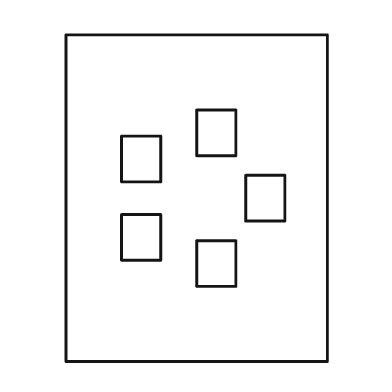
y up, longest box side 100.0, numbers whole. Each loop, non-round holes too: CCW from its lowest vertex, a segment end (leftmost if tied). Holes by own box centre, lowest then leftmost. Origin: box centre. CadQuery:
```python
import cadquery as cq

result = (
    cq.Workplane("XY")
    .moveTo(-40.0, -50.0)
    .lineTo(40.0, -50.0)
    .lineTo(40.0, 50.0)
    .lineTo(-40.0, 50.0)
    .close()
    .moveTo(0.0, -27.0)
    .lineTo(12.0, -27.0)
    .lineTo(12.0, -13.0)
    .lineTo(0.0, -13.0)
    .close()
    .moveTo(-23.0, -19.0)
    .lineTo(-11.0, -19.0)
    .lineTo(-11.0, -5.0)
    .lineTo(-23.0, -5.0)
    .close()
    .moveTo(15.0, -7.0)
    .lineTo(27.0, -7.0)
    .lineTo(27.0, 7.0)
    .lineTo(15.0, 7.0)
    .close()
    .moveTo(-23.0, 5.0)
    .lineTo(-11.0, 5.0)
    .lineTo(-11.0, 19.0)
    .lineTo(-23.0, 19.0)
    .close()
    .moveTo(0.0, 13.0)
    .lineTo(12.0, 13.0)
    .lineTo(12.0, 27.0)
    .lineTo(0.0, 27.0)
    .close()
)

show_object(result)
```